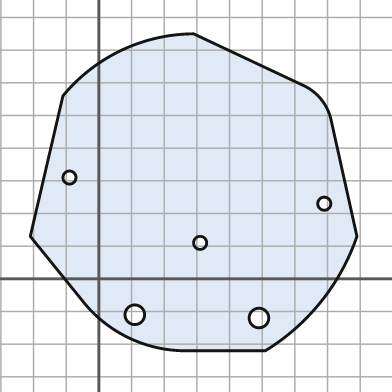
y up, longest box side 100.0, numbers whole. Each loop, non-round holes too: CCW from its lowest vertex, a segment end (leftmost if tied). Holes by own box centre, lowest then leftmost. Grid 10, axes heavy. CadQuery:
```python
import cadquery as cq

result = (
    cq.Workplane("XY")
    .moveTo(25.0, -22.0)
    .lineTo(51.0, -22.0)
    .threePointArc((68.0, -7.0), (79.0, 13.0))
    .lineTo(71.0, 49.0)
    .threePointArc((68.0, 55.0), (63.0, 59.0))
    .lineTo(29.0, 75.0)
    .threePointArc((7.0, 70.0), (-11.0, 56.0))
    .lineTo(-21.0, 13.0)
    .lineTo(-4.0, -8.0)
    .threePointArc((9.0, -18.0), (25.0, -22.0))
    .close()
    .moveTo(49.0, -12.0)
    .circle(3.0)
    .moveTo(11.0, -11.0)
    .circle(3.0)
    .moveTo(31.0, 11.0)
    .circle(2.0)
    .moveTo(69.0, 23.0)
    .circle(2.0)
    .moveTo(-9.0, 31.0)
    .circle(2.0)
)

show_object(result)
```